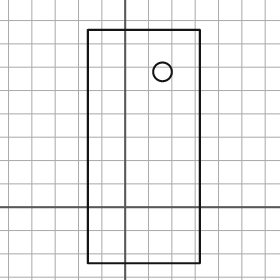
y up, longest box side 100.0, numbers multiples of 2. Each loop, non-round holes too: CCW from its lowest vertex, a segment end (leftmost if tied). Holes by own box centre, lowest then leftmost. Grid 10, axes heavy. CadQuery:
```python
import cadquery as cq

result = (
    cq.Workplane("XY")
    .moveTo(-16.0, -24.0)
    .lineTo(32.0, -24.0)
    .lineTo(32.0, 76.0)
    .lineTo(-16.0, 76.0)
    .close()
    .moveTo(16.0, 58.0)
    .circle(4.0)
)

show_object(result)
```